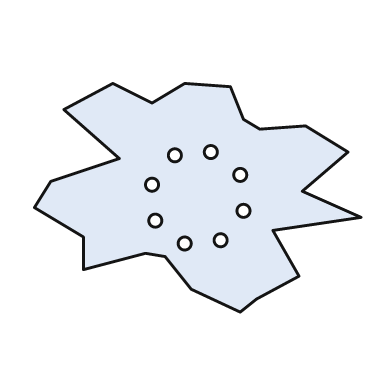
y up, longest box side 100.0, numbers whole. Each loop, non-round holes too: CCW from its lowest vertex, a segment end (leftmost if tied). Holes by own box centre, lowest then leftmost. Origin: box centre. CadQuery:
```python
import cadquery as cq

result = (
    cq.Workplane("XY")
    .moveTo(13.0, -35.0)
    .lineTo(18.0, -31.0)
    .lineTo(31.0, -24.0)
    .lineTo(23.0, -10.0)
    .lineTo(50.0, -6.0)
    .lineTo(32.0, 2.0)
    .lineTo(46.0, 14.0)
    .lineTo(33.0, 22.0)
    .lineTo(19.0, 21.0)
    .lineTo(14.0, 24.0)
    .lineTo(10.0, 34.0)
    .lineTo(-4.0, 35.0)
    .lineTo(-14.0, 29.0)
    .lineTo(-26.0, 35.0)
    .lineTo(-41.0, 27.0)
    .lineTo(-24.0, 12.0)
    .lineTo(-45.0, 5.0)
    .lineTo(-50.0, -3.0)
    .lineTo(-35.0, -12.0)
    .lineTo(-35.0, -22.0)
    .lineTo(-16.0, -17.0)
    .lineTo(-10.0, -18.0)
    .lineTo(-2.0, -28.0)
    .close()
    .moveTo(-4.0, -14.0)
    .circle(2.0)
    .moveTo(7.0, -13.0)
    .circle(2.0)
    .moveTo(-13.0, -7.0)
    .circle(2.0)
    .moveTo(14.0, -4.0)
    .circle(2.0)
    .moveTo(-14.0, 4.0)
    .circle(2.0)
    .moveTo(13.0, 7.0)
    .circle(2.0)
    .moveTo(-7.0, 13.0)
    .circle(2.0)
    .moveTo(4.0, 14.0)
    .circle(2.0)
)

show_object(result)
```